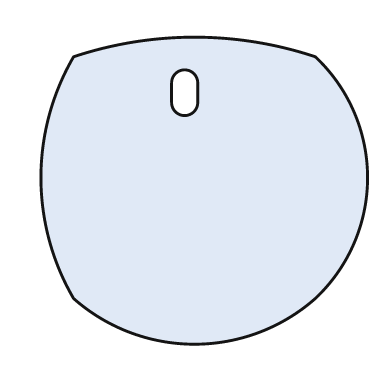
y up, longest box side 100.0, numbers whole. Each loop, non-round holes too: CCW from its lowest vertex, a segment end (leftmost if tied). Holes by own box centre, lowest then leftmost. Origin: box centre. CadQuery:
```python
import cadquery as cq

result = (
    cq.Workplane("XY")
    .moveTo(-40.0, -33.0)
    .threePointArc((-3.0, -47.0), (34.0, -33.0))
    .threePointArc((50.0, 4.0), (34.0, 41.0))
    .threePointArc((-3.0, 47.0), (-40.0, 41.0))
    .threePointArc((-50.0, 4.0), (-40.0, -33.0))
    .close()
    .moveTo(-10.0, 27.0)
    .threePointArc((-6.0, 23.0), (-2.0, 27.0))
    .lineTo(-2.0, 33.0)
    .threePointArc((-6.0, 37.0), (-10.0, 33.0))
    .close()
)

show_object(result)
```